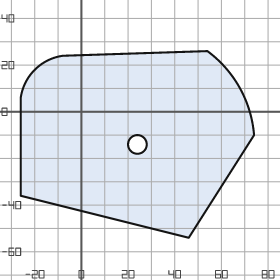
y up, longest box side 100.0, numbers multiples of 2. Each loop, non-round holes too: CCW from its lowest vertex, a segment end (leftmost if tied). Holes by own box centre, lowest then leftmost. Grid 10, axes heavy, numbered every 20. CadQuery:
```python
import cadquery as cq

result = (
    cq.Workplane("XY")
    .moveTo(46.0, -54.0)
    .lineTo(74.0, -10.0)
    .threePointArc((68.0, 10.0), (54.0, 26.0))
    .lineTo(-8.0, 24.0)
    .threePointArc((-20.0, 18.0), (-26.0, 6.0))
    .lineTo(-26.0, -36.0)
    .close()
    .moveTo(24.0, -14.0)
    .circle(4.0)
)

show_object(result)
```